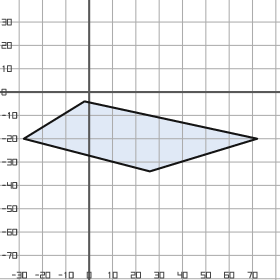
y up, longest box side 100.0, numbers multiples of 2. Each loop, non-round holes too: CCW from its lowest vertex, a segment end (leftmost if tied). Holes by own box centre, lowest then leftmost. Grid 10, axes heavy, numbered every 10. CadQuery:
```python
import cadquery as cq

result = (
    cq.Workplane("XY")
    .moveTo(26.0, -34.0)
    .lineTo(72.0, -20.0)
    .lineTo(-2.0, -4.0)
    .lineTo(-28.0, -20.0)
    .close()
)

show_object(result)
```